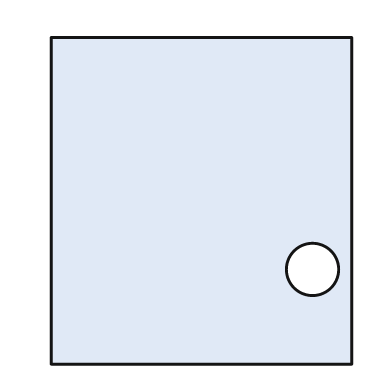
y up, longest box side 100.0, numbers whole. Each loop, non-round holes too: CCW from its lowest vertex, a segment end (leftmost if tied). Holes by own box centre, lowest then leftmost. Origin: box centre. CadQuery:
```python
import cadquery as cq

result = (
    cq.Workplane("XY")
    .moveTo(-46.0, -50.0)
    .lineTo(46.0, -50.0)
    .lineTo(46.0, 50.0)
    .lineTo(-46.0, 50.0)
    .close()
    .moveTo(34.0, -21.0)
    .circle(8.0)
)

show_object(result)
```